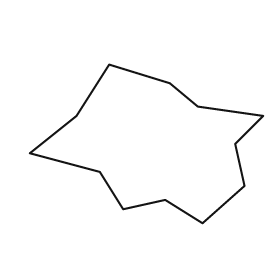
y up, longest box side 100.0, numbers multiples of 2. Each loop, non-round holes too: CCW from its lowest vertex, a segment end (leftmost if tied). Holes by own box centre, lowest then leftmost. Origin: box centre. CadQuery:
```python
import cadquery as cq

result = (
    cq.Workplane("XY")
    .moveTo(24.0, -34.0)
    .lineTo(42.0, -18.0)
    .lineTo(38.0, 0.0)
    .lineTo(50.0, 12.0)
    .lineTo(22.0, 16.0)
    .lineTo(10.0, 26.0)
    .lineTo(-16.0, 34.0)
    .lineTo(-30.0, 12.0)
    .lineTo(-50.0, -4.0)
    .lineTo(-20.0, -12.0)
    .lineTo(-10.0, -28.0)
    .lineTo(8.0, -24.0)
    .close()
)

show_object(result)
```